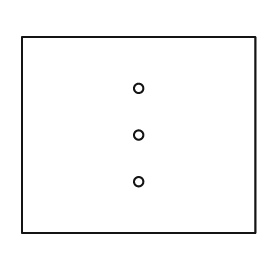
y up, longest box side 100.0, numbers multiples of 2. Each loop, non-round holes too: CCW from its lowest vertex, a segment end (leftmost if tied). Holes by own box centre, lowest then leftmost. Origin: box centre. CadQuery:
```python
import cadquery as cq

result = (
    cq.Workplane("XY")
    .moveTo(-50.0, -42.0)
    .lineTo(50.0, -42.0)
    .lineTo(50.0, 42.0)
    .lineTo(-50.0, 42.0)
    .close()
    .moveTo(0.0, -20.0)
    .circle(2.0)
    .moveTo(0.0, 0.0)
    .circle(2.0)
    .moveTo(0.0, 20.0)
    .circle(2.0)
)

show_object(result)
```